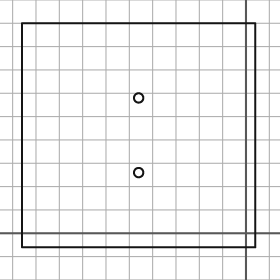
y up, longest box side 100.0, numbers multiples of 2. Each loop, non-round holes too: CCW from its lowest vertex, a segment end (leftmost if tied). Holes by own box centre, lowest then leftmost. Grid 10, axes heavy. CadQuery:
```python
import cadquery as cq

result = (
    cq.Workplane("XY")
    .moveTo(-96.0, -6.0)
    .lineTo(4.0, -6.0)
    .lineTo(4.0, 90.0)
    .lineTo(-96.0, 90.0)
    .close()
    .moveTo(-46.0, 26.0)
    .circle(2.0)
    .moveTo(-46.0, 58.0)
    .circle(2.0)
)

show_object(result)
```